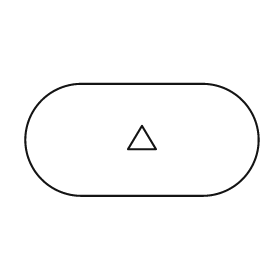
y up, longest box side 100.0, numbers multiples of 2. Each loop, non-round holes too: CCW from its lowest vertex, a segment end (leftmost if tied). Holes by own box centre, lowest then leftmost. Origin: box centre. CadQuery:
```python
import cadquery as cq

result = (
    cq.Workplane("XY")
    .moveTo(-26.0, -24.0)
    .lineTo(26.0, -24.0)
    .threePointArc((50.0, 0.0), (26.0, 24.0))
    .lineTo(-26.0, 24.0)
    .threePointArc((-50.0, 0.0), (-26.0, -24.0))
    .close()
    .moveTo(-6.0, -4.0)
    .lineTo(6.0, -4.0)
    .lineTo(0.0, 6.0)
    .close()
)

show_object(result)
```